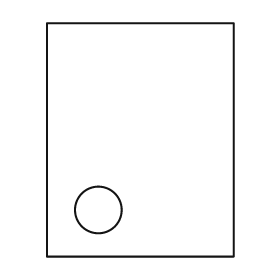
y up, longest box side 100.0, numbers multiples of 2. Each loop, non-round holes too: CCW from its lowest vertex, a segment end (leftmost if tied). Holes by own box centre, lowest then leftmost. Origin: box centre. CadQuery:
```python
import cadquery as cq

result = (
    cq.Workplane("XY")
    .moveTo(-40.0, -50.0)
    .lineTo(40.0, -50.0)
    .lineTo(40.0, 50.0)
    .lineTo(-40.0, 50.0)
    .close()
    .moveTo(-18.0, -30.0)
    .circle(10.0)
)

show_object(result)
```